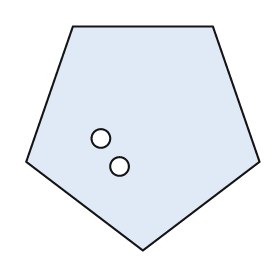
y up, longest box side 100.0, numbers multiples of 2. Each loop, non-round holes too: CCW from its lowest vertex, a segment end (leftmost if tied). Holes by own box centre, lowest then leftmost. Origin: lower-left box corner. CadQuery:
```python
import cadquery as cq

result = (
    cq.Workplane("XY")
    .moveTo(50.0, 0.0)
    .lineTo(100.0, 38.0)
    .lineTo(80.0, 96.0)
    .lineTo(20.0, 96.0)
    .lineTo(0.0, 38.0)
    .close()
    .moveTo(40.0, 36.0)
    .circle(4.0)
    .moveTo(32.0, 48.0)
    .circle(4.0)
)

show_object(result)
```